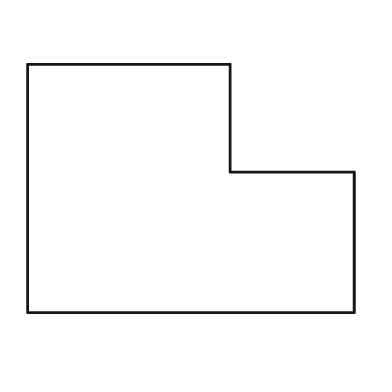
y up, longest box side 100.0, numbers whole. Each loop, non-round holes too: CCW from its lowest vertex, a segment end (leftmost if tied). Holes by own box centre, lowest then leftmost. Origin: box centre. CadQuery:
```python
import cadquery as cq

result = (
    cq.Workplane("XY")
    .moveTo(-50.0, -38.0)
    .lineTo(50.0, -38.0)
    .lineTo(50.0, 5.0)
    .lineTo(12.0, 5.0)
    .lineTo(12.0, 38.0)
    .lineTo(-50.0, 38.0)
    .close()
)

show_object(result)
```